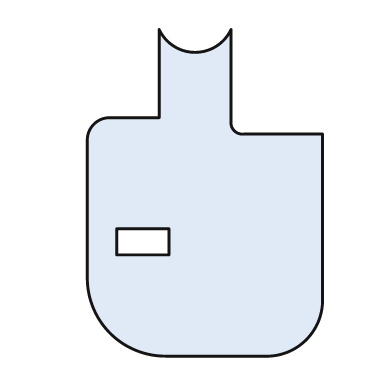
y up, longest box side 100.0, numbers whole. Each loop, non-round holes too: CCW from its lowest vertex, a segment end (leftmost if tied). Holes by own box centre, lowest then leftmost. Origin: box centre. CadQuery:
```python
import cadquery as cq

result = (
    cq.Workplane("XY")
    .moveTo(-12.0, -50.0)
    .lineTo(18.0, -50.0)
    .threePointArc((31.0, -45.0), (36.0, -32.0))
    .lineTo(36.0, 18.0)
    .lineTo(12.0, 18.0)
    .threePointArc((9.0, 19.0), (8.0, 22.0))
    .lineTo(8.0, 50.0)
    .threePointArc((-3.0, 43.0), (-14.0, 50.0))
    .lineTo(-14.0, 23.0)
    .lineTo(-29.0, 23.0)
    .threePointArc((-34.0, 21.0), (-36.0, 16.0))
    .lineTo(-36.0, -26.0)
    .threePointArc((-29.0, -43.0), (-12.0, -50.0))
    .close()
    .moveTo(-27.0, -19.0)
    .lineTo(-11.0, -19.0)
    .lineTo(-11.0, -11.0)
    .lineTo(-27.0, -11.0)
    .close()
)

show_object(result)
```